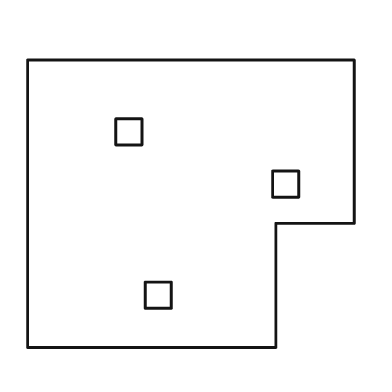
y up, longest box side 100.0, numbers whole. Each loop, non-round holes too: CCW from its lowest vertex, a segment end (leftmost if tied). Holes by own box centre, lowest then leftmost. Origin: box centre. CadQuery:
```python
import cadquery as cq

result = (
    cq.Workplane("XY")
    .moveTo(-50.0, -44.0)
    .lineTo(26.0, -44.0)
    .lineTo(26.0, -6.0)
    .lineTo(50.0, -6.0)
    .lineTo(50.0, 44.0)
    .lineTo(-50.0, 44.0)
    .close()
    .moveTo(-14.0, -32.0)
    .lineTo(-6.0, -32.0)
    .lineTo(-6.0, -24.0)
    .lineTo(-14.0, -24.0)
    .close()
    .moveTo(25.0, 2.0)
    .lineTo(33.0, 2.0)
    .lineTo(33.0, 10.0)
    .lineTo(25.0, 10.0)
    .close()
    .moveTo(-23.0, 18.0)
    .lineTo(-15.0, 18.0)
    .lineTo(-15.0, 26.0)
    .lineTo(-23.0, 26.0)
    .close()
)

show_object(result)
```